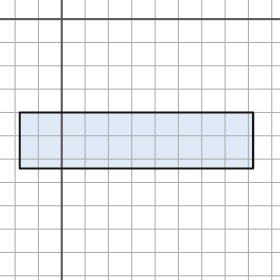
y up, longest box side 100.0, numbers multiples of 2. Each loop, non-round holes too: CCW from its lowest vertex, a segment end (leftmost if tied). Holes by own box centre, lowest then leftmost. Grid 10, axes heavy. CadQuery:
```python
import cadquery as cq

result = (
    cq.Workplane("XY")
    .moveTo(-18.0, -64.0)
    .lineTo(82.0, -64.0)
    .lineTo(82.0, -40.0)
    .lineTo(-18.0, -40.0)
    .close()
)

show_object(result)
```